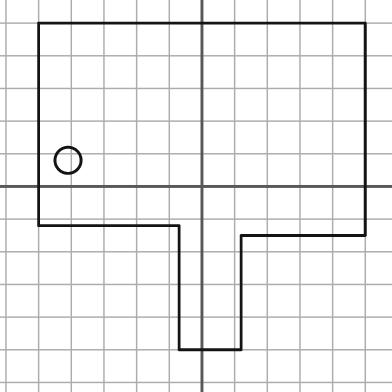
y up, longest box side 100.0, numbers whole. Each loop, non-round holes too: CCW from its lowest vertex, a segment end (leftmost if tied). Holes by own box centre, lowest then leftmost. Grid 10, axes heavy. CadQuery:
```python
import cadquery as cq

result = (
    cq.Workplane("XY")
    .moveTo(-7.0, -50.0)
    .lineTo(12.0, -50.0)
    .lineTo(12.0, -15.0)
    .lineTo(50.0, -15.0)
    .lineTo(50.0, 50.0)
    .lineTo(-50.0, 50.0)
    .lineTo(-50.0, -12.0)
    .lineTo(-7.0, -12.0)
    .close()
    .moveTo(-41.0, 8.0)
    .circle(4.0)
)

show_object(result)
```